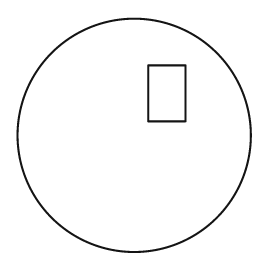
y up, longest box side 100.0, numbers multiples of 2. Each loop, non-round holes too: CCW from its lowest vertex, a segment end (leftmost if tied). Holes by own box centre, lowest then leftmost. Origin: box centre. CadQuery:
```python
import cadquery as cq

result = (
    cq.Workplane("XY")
    .moveTo(0.0, 0.0)
    .circle(50.0)
    .moveTo(6.0, 6.0)
    .lineTo(22.0, 6.0)
    .lineTo(22.0, 30.0)
    .lineTo(6.0, 30.0)
    .close()
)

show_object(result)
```